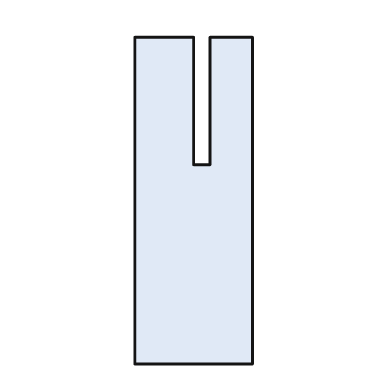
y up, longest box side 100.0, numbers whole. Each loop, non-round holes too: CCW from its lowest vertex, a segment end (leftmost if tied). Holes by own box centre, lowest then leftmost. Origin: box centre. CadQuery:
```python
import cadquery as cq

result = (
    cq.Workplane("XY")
    .moveTo(-18.0, -50.0)
    .lineTo(18.0, -50.0)
    .lineTo(18.0, 50.0)
    .lineTo(5.0, 50.0)
    .lineTo(5.0, 11.0)
    .lineTo(0.0, 11.0)
    .lineTo(0.0, 50.0)
    .lineTo(-18.0, 50.0)
    .close()
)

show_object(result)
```